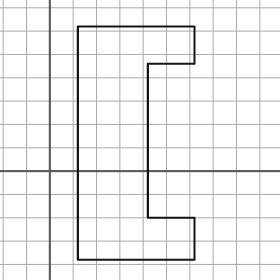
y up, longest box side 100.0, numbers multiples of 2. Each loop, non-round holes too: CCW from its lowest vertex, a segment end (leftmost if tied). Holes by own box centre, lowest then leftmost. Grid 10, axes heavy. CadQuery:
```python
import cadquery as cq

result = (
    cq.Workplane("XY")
    .moveTo(12.0, -38.0)
    .lineTo(62.0, -38.0)
    .lineTo(62.0, -20.0)
    .lineTo(42.0, -20.0)
    .lineTo(42.0, 46.0)
    .lineTo(62.0, 46.0)
    .lineTo(62.0, 62.0)
    .lineTo(12.0, 62.0)
    .close()
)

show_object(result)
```